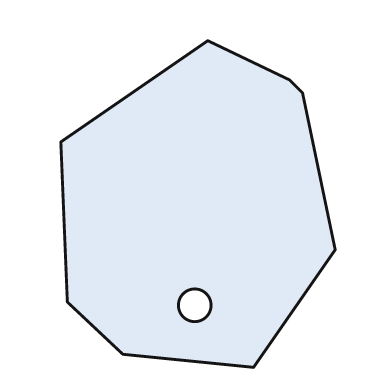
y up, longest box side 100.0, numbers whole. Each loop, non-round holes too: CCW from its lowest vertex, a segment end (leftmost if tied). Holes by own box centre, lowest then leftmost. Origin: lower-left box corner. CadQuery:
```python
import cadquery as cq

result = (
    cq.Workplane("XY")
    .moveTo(59.0, 0.0)
    .lineTo(84.0, 36.0)
    .lineTo(74.0, 84.0)
    .lineTo(70.0, 88.0)
    .lineTo(45.0, 100.0)
    .lineTo(0.0, 69.0)
    .lineTo(2.0, 20.0)
    .lineTo(19.0, 4.0)
    .close()
    .moveTo(41.0, 19.0)
    .circle(5.0)
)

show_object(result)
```